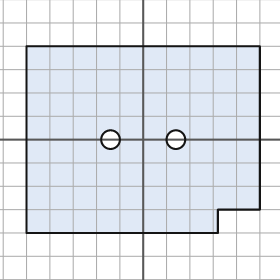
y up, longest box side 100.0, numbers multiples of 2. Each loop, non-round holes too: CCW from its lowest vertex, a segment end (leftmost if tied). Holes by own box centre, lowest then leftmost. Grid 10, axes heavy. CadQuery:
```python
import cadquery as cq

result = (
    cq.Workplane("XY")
    .moveTo(-50.0, -40.0)
    .lineTo(32.0, -40.0)
    .lineTo(32.0, -30.0)
    .lineTo(50.0, -30.0)
    .lineTo(50.0, 40.0)
    .lineTo(-50.0, 40.0)
    .close()
    .moveTo(-14.0, 0.0)
    .circle(4.0)
    .moveTo(14.0, 0.0)
    .circle(4.0)
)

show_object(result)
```